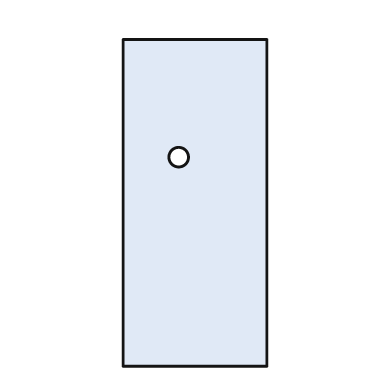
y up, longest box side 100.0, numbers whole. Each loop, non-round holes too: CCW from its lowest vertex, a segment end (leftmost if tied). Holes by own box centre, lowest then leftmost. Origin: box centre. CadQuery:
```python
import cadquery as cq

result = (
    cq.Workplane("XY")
    .moveTo(-22.0, -50.0)
    .lineTo(22.0, -50.0)
    .lineTo(22.0, 50.0)
    .lineTo(-22.0, 50.0)
    .close()
    .moveTo(-5.0, 14.0)
    .circle(3.0)
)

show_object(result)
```